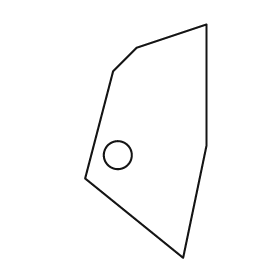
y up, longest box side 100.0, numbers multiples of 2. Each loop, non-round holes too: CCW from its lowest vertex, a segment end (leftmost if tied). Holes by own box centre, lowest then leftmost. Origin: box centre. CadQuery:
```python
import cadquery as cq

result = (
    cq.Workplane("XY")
    .moveTo(16.0, -50.0)
    .lineTo(26.0, -2.0)
    .lineTo(26.0, 50.0)
    .lineTo(-4.0, 40.0)
    .lineTo(-14.0, 30.0)
    .lineTo(-26.0, -16.0)
    .close()
    .moveTo(-12.0, -6.0)
    .circle(6.0)
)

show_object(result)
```